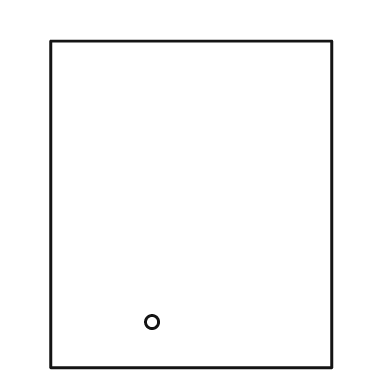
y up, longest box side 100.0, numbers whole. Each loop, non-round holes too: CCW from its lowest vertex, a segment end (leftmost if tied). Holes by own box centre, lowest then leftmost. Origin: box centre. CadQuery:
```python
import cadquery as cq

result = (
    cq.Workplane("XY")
    .moveTo(-43.0, -50.0)
    .lineTo(43.0, -50.0)
    .lineTo(43.0, 50.0)
    .lineTo(-43.0, 50.0)
    .close()
    .moveTo(-12.0, -36.0)
    .circle(2.0)
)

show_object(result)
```